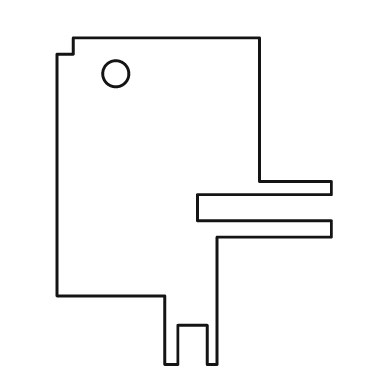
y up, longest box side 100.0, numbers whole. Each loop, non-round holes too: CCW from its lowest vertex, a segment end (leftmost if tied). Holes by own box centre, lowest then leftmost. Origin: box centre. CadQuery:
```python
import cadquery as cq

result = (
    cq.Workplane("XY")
    .moveTo(-9.0, -50.0)
    .lineTo(-5.0, -50.0)
    .lineTo(-5.0, -38.0)
    .lineTo(4.0, -38.0)
    .lineTo(4.0, -50.0)
    .lineTo(7.0, -50.0)
    .lineTo(7.0, -11.0)
    .lineTo(42.0, -11.0)
    .lineTo(42.0, -6.0)
    .lineTo(1.0, -6.0)
    .lineTo(1.0, 2.0)
    .lineTo(42.0, 2.0)
    .lineTo(42.0, 6.0)
    .lineTo(20.0, 6.0)
    .lineTo(20.0, 50.0)
    .lineTo(-37.0, 50.0)
    .lineTo(-37.0, 45.0)
    .lineTo(-42.0, 45.0)
    .lineTo(-42.0, -29.0)
    .lineTo(-9.0, -29.0)
    .close()
    .moveTo(-24.0, 39.0)
    .circle(4.0)
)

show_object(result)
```